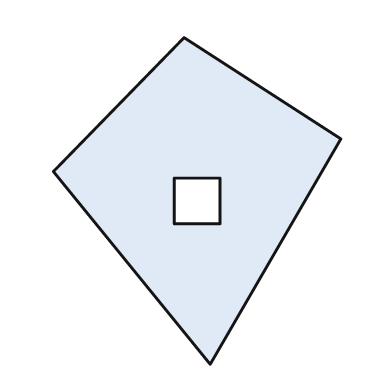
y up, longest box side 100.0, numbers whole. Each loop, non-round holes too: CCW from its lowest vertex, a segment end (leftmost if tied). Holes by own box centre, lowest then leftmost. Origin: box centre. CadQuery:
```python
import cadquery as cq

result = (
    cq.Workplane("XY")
    .moveTo(4.0, -50.0)
    .lineTo(44.0, 19.0)
    .lineTo(-4.0, 50.0)
    .lineTo(-44.0, 9.0)
    .close()
    .moveTo(-7.0, -7.0)
    .lineTo(7.0, -7.0)
    .lineTo(7.0, 7.0)
    .lineTo(-7.0, 7.0)
    .close()
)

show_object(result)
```